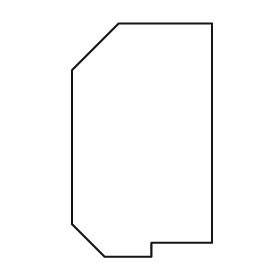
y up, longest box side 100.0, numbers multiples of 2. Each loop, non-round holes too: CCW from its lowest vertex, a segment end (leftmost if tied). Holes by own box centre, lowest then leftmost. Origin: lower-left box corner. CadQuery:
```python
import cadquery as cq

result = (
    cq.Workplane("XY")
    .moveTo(14.0, 0.0)
    .lineTo(34.0, 0.0)
    .lineTo(34.0, 6.0)
    .lineTo(60.0, 6.0)
    .lineTo(60.0, 100.0)
    .lineTo(20.0, 100.0)
    .lineTo(0.0, 80.0)
    .lineTo(0.0, 14.0)
    .close()
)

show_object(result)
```